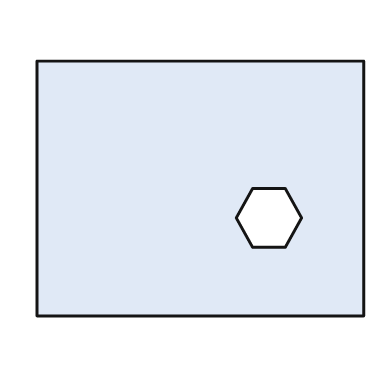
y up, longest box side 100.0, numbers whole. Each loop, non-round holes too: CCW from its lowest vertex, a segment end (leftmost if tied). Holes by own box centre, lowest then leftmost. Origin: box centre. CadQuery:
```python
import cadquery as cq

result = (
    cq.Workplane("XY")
    .moveTo(-50.0, -39.0)
    .lineTo(50.0, -39.0)
    .lineTo(50.0, 39.0)
    .lineTo(-50.0, 39.0)
    .close()
    .moveTo(16.0, -18.0)
    .lineTo(26.0, -18.0)
    .lineTo(31.0, -9.0)
    .lineTo(26.0, 0.0)
    .lineTo(16.0, 0.0)
    .lineTo(11.0, -9.0)
    .close()
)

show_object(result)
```